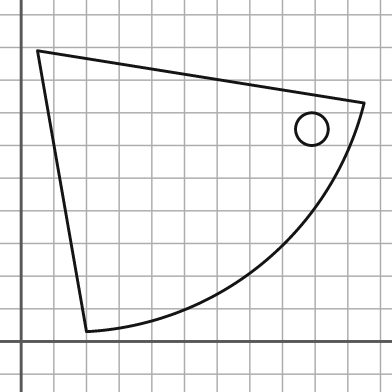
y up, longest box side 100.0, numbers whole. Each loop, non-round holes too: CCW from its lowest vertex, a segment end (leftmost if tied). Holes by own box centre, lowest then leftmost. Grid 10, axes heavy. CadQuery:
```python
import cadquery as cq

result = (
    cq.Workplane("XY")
    .moveTo(20.0, 3.0)
    .threePointArc((74.0, 24.0), (105.0, 73.0))
    .lineTo(5.0, 89.0)
    .close()
    .moveTo(89.0, 65.0)
    .circle(5.0)
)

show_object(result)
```